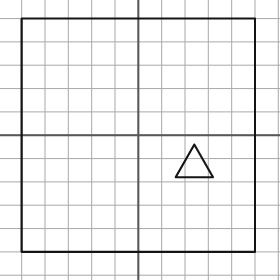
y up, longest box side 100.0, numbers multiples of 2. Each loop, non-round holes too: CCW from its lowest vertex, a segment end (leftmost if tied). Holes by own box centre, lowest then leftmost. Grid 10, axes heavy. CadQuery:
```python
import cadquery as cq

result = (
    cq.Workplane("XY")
    .moveTo(-50.0, -50.0)
    .lineTo(50.0, -50.0)
    .lineTo(50.0, 50.0)
    .lineTo(-50.0, 50.0)
    .close()
    .moveTo(16.0, -18.0)
    .lineTo(32.0, -18.0)
    .lineTo(24.0, -4.0)
    .close()
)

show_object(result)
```